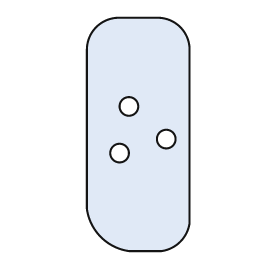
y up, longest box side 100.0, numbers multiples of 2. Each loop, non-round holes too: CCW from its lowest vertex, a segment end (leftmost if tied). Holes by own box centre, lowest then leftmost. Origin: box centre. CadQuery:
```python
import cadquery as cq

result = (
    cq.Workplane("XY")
    .moveTo(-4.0, -50.0)
    .lineTo(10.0, -50.0)
    .threePointArc((18.0, -46.0), (22.0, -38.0))
    .lineTo(22.0, 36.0)
    .threePointArc((18.0, 46.0), (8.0, 50.0))
    .lineTo(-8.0, 50.0)
    .threePointArc((-18.0, 46.0), (-22.0, 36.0))
    .lineTo(-22.0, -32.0)
    .threePointArc((-16.0, -44.0), (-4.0, -50.0))
    .close()
    .moveTo(-8.0, -8.0)
    .circle(4.0)
    .moveTo(12.0, -2.0)
    .circle(4.0)
    .moveTo(-4.0, 12.0)
    .circle(4.0)
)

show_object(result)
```